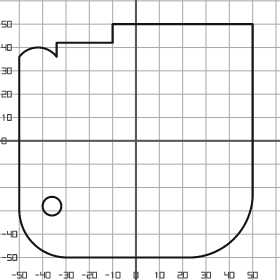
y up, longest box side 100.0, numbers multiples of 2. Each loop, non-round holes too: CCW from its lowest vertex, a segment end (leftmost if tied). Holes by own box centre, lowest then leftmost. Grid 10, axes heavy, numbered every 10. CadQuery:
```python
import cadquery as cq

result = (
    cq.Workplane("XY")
    .moveTo(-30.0, -50.0)
    .lineTo(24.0, -50.0)
    .threePointArc((42.0, -42.0), (50.0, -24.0))
    .lineTo(50.0, 50.0)
    .lineTo(-10.0, 50.0)
    .lineTo(-10.0, 42.0)
    .lineTo(-34.0, 42.0)
    .lineTo(-34.0, 36.0)
    .threePointArc((-42.0, 40.0), (-50.0, 36.0))
    .lineTo(-50.0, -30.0)
    .threePointArc((-44.0, -44.0), (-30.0, -50.0))
    .close()
    .moveTo(-36.0, -28.0)
    .circle(4.0)
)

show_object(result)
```